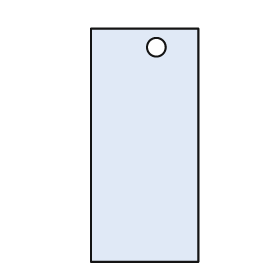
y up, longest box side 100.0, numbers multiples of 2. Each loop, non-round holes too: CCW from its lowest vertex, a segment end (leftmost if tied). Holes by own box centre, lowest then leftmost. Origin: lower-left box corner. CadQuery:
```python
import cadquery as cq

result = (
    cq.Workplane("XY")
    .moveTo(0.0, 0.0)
    .lineTo(46.0, 0.0)
    .lineTo(46.0, 100.0)
    .lineTo(0.0, 100.0)
    .close()
    .moveTo(28.0, 92.0)
    .circle(4.0)
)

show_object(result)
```